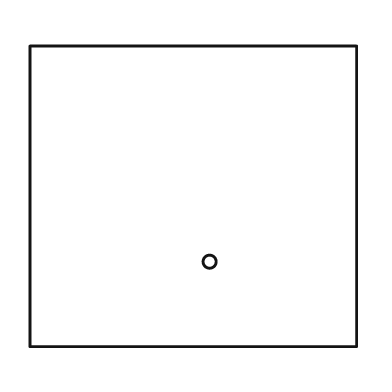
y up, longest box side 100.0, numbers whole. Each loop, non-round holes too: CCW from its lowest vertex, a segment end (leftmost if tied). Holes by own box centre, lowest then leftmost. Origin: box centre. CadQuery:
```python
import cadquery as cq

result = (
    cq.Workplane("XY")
    .moveTo(-50.0, -46.0)
    .lineTo(50.0, -46.0)
    .lineTo(50.0, 46.0)
    .lineTo(-50.0, 46.0)
    .close()
    .moveTo(5.0, -20.0)
    .circle(2.0)
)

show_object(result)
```